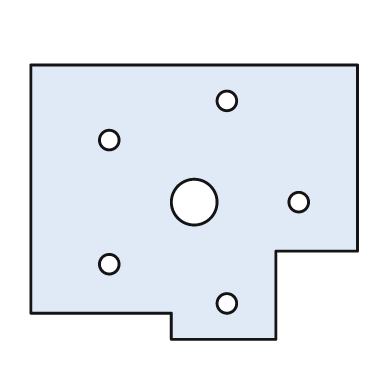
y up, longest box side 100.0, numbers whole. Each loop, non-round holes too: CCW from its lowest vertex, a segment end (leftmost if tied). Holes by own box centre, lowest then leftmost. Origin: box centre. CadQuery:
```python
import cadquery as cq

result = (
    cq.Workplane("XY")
    .moveTo(-7.0, -42.0)
    .lineTo(25.0, -42.0)
    .lineTo(25.0, -15.0)
    .lineTo(50.0, -15.0)
    .lineTo(50.0, 42.0)
    .lineTo(-50.0, 42.0)
    .lineTo(-50.0, -34.0)
    .lineTo(-7.0, -34.0)
    .close()
    .moveTo(10.0, -31.0)
    .circle(3.0)
    .moveTo(-26.0, -19.0)
    .circle(3.0)
    .moveTo(0.0, 0.0)
    .circle(7.0)
    .moveTo(32.0, 0.0)
    .circle(3.0)
    .moveTo(-26.0, 19.0)
    .circle(3.0)
    .moveTo(10.0, 31.0)
    .circle(3.0)
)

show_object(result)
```